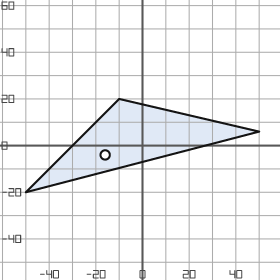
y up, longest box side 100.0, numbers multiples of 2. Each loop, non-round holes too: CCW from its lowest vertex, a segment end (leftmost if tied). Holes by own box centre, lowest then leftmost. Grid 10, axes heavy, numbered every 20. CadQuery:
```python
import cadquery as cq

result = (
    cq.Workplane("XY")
    .moveTo(-50.0, -20.0)
    .lineTo(50.0, 6.0)
    .lineTo(-10.0, 20.0)
    .close()
    .moveTo(-16.0, -4.0)
    .circle(2.0)
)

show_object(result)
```